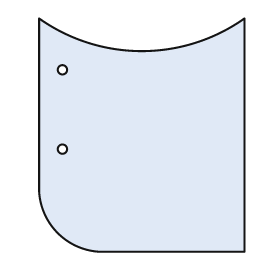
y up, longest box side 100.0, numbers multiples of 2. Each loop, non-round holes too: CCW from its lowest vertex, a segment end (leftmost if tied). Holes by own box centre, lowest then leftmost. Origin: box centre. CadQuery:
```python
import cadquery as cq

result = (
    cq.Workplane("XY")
    .moveTo(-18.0, -50.0)
    .lineTo(44.0, -50.0)
    .lineTo(44.0, 50.0)
    .threePointArc((0.0, 36.0), (-44.0, 50.0))
    .lineTo(-44.0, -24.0)
    .threePointArc((-36.0, -42.0), (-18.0, -50.0))
    .close()
    .moveTo(-34.0, -6.0)
    .circle(2.0)
    .moveTo(-34.0, 28.0)
    .circle(2.0)
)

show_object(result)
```